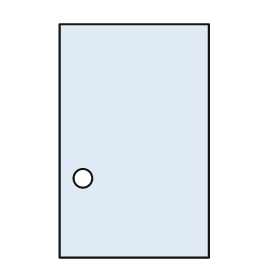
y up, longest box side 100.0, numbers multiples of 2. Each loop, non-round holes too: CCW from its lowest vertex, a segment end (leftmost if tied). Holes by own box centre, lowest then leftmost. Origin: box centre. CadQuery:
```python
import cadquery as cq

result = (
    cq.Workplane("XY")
    .moveTo(-32.0, -50.0)
    .lineTo(32.0, -50.0)
    .lineTo(32.0, 50.0)
    .lineTo(-32.0, 50.0)
    .close()
    .moveTo(-22.0, -16.0)
    .circle(4.0)
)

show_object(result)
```